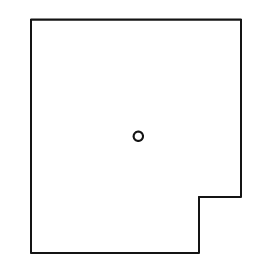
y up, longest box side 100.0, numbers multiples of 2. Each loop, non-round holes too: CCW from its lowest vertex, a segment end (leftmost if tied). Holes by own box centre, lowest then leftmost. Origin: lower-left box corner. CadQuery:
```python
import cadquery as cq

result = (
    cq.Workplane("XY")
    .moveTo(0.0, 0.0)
    .lineTo(72.0, 0.0)
    .lineTo(72.0, 24.0)
    .lineTo(90.0, 24.0)
    .lineTo(90.0, 100.0)
    .lineTo(0.0, 100.0)
    .close()
    .moveTo(46.0, 50.0)
    .circle(2.0)
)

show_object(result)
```